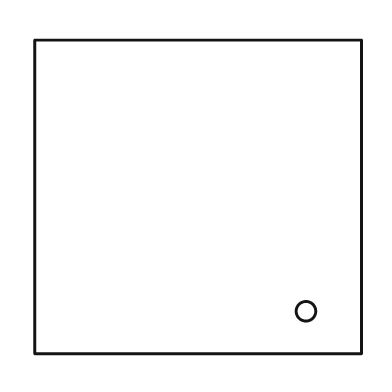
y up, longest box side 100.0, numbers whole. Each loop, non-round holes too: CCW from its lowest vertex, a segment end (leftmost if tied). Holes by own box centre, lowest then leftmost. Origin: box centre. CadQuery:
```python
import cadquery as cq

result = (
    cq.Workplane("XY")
    .moveTo(-50.0, -48.0)
    .lineTo(50.0, -48.0)
    .lineTo(50.0, 48.0)
    .lineTo(-50.0, 48.0)
    .close()
    .moveTo(33.0, -35.0)
    .circle(3.0)
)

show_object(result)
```